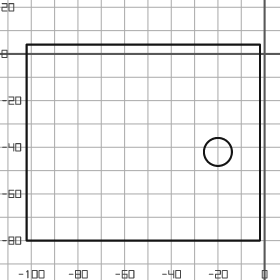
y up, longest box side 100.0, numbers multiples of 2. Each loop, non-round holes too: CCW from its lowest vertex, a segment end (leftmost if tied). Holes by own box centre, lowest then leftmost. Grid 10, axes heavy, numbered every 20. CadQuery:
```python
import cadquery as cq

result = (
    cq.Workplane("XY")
    .moveTo(-102.0, -80.0)
    .lineTo(-2.0, -80.0)
    .lineTo(-2.0, 4.0)
    .lineTo(-102.0, 4.0)
    .close()
    .moveTo(-20.0, -42.0)
    .circle(6.0)
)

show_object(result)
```